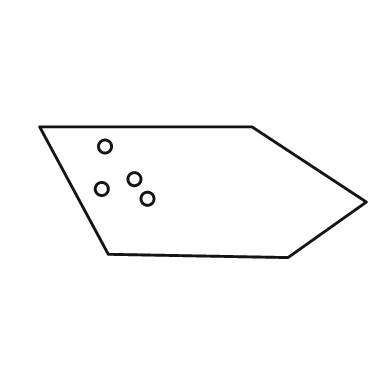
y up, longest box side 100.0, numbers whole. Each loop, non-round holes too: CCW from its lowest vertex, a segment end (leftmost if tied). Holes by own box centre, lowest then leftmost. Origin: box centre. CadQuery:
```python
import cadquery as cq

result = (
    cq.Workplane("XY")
    .moveTo(26.0, -20.0)
    .lineTo(50.0, -3.0)
    .lineTo(15.0, 20.0)
    .lineTo(-50.0, 20.0)
    .lineTo(-29.0, -19.0)
    .close()
    .moveTo(-17.0, -2.0)
    .circle(2.0)
    .moveTo(-31.0, 1.0)
    .circle(2.0)
    .moveTo(-21.0, 4.0)
    .circle(2.0)
    .moveTo(-30.0, 14.0)
    .circle(2.0)
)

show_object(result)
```